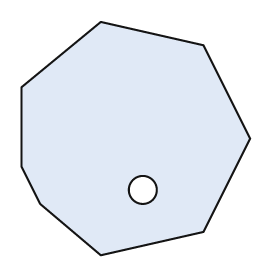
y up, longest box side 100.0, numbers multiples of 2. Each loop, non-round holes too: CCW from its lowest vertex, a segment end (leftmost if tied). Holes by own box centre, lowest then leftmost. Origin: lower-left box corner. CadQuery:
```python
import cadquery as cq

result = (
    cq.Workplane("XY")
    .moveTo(34.0, 0.0)
    .lineTo(78.0, 10.0)
    .lineTo(98.0, 50.0)
    .lineTo(78.0, 90.0)
    .lineTo(34.0, 100.0)
    .lineTo(0.0, 72.0)
    .lineTo(0.0, 38.0)
    .lineTo(8.0, 22.0)
    .close()
    .moveTo(52.0, 28.0)
    .circle(6.0)
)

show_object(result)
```